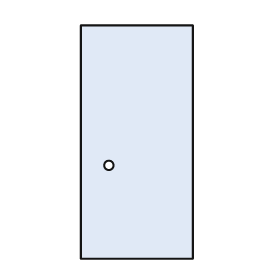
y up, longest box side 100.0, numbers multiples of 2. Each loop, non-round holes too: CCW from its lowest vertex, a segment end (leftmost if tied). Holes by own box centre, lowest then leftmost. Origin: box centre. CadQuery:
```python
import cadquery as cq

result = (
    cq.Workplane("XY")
    .moveTo(-24.0, -50.0)
    .lineTo(24.0, -50.0)
    .lineTo(24.0, 50.0)
    .lineTo(-24.0, 50.0)
    .close()
    .moveTo(-12.0, -10.0)
    .circle(2.0)
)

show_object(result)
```